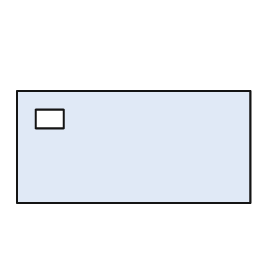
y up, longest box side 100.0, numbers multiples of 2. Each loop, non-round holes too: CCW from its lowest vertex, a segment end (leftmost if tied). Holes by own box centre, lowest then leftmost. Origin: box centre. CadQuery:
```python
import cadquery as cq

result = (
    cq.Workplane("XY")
    .moveTo(-50.0, -24.0)
    .lineTo(50.0, -24.0)
    .lineTo(50.0, 24.0)
    .lineTo(-50.0, 24.0)
    .close()
    .moveTo(-42.0, 8.0)
    .lineTo(-30.0, 8.0)
    .lineTo(-30.0, 16.0)
    .lineTo(-42.0, 16.0)
    .close()
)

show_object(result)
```